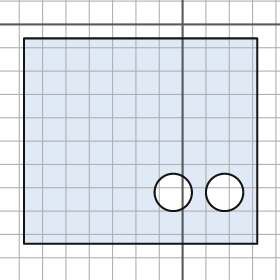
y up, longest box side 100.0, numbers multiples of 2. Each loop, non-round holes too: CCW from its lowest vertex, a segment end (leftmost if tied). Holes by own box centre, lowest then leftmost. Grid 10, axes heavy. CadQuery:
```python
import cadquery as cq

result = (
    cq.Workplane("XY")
    .moveTo(-68.0, -94.0)
    .lineTo(32.0, -94.0)
    .lineTo(32.0, -6.0)
    .lineTo(-68.0, -6.0)
    .close()
    .moveTo(-4.0, -72.0)
    .circle(8.0)
    .moveTo(18.0, -72.0)
    .circle(8.0)
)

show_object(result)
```